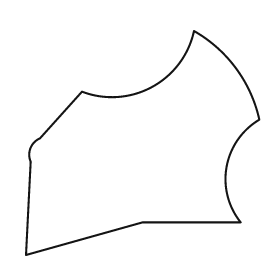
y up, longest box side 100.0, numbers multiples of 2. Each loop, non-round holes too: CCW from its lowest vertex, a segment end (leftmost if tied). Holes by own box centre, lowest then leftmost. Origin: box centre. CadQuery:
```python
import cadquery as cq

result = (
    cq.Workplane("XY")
    .moveTo(-50.0, -48.0)
    .lineTo(0.0, -34.0)
    .lineTo(42.0, -34.0)
    .threePointArc((36.0, -10.0), (50.0, 10.0))
    .threePointArc((40.0, 32.0), (22.0, 48.0))
    .threePointArc((4.0, 24.0), (-26.0, 22.0))
    .lineTo(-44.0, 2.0)
    .threePointArc((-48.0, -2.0), (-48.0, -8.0))
    .close()
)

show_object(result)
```